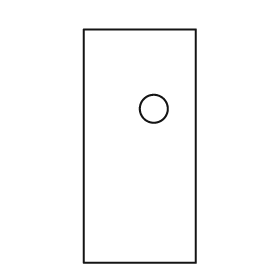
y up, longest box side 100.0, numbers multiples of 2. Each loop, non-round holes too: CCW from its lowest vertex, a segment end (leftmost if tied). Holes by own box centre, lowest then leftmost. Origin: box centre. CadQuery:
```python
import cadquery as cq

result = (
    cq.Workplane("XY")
    .moveTo(-24.0, -50.0)
    .lineTo(24.0, -50.0)
    .lineTo(24.0, 50.0)
    .lineTo(-24.0, 50.0)
    .close()
    .moveTo(6.0, 16.0)
    .circle(6.0)
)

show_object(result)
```